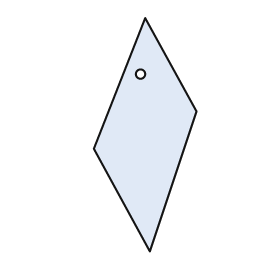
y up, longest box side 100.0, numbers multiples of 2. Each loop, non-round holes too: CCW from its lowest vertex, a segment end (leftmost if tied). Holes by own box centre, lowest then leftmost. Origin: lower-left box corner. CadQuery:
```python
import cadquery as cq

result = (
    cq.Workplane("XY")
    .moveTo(24.0, 0.0)
    .lineTo(44.0, 60.0)
    .lineTo(22.0, 100.0)
    .lineTo(0.0, 44.0)
    .close()
    .moveTo(20.0, 76.0)
    .circle(2.0)
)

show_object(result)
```